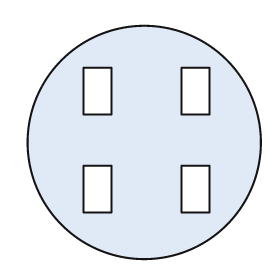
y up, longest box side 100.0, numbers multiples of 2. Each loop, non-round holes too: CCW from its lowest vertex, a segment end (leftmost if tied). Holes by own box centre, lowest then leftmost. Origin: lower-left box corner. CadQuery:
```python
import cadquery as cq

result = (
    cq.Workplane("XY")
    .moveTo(50.0, 50.0)
    .circle(50.0)
    .moveTo(24.0, 20.0)
    .lineTo(36.0, 20.0)
    .lineTo(36.0, 40.0)
    .lineTo(24.0, 40.0)
    .close()
    .moveTo(66.0, 20.0)
    .lineTo(78.0, 20.0)
    .lineTo(78.0, 40.0)
    .lineTo(66.0, 40.0)
    .close()
    .moveTo(24.0, 62.0)
    .lineTo(36.0, 62.0)
    .lineTo(36.0, 82.0)
    .lineTo(24.0, 82.0)
    .close()
    .moveTo(66.0, 62.0)
    .lineTo(78.0, 62.0)
    .lineTo(78.0, 82.0)
    .lineTo(66.0, 82.0)
    .close()
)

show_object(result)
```